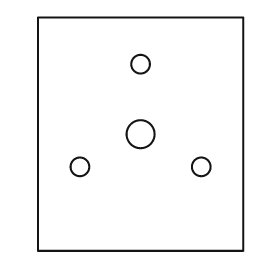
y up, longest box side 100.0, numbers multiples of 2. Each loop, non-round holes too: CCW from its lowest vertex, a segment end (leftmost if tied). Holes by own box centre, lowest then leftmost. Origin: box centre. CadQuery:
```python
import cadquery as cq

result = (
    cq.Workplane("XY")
    .moveTo(-44.0, -50.0)
    .lineTo(44.0, -50.0)
    .lineTo(44.0, 50.0)
    .lineTo(-44.0, 50.0)
    .close()
    .moveTo(-26.0, -14.0)
    .circle(4.0)
    .moveTo(26.0, -14.0)
    .circle(4.0)
    .moveTo(0.0, 0.0)
    .circle(6.0)
    .moveTo(0.0, 30.0)
    .circle(4.0)
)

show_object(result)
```